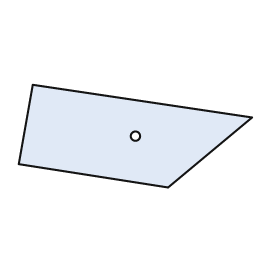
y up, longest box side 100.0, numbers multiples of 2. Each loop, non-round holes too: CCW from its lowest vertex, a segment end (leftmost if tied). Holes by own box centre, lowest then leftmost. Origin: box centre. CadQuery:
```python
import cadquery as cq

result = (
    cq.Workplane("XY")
    .moveTo(14.0, -22.0)
    .lineTo(50.0, 8.0)
    .lineTo(-44.0, 22.0)
    .lineTo(-50.0, -12.0)
    .close()
    .moveTo(0.0, 0.0)
    .circle(2.0)
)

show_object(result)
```